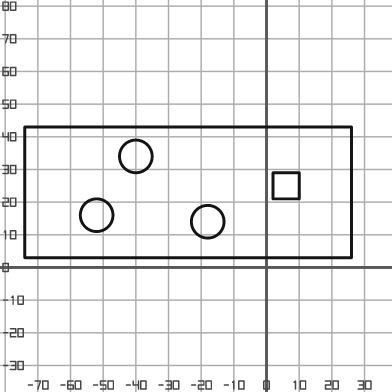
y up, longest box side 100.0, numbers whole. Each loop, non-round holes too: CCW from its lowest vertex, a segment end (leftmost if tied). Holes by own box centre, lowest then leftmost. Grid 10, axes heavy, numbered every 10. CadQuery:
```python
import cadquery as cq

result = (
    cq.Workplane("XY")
    .moveTo(-74.0, 3.0)
    .lineTo(26.0, 3.0)
    .lineTo(26.0, 43.0)
    .lineTo(-74.0, 43.0)
    .close()
    .moveTo(-18.0, 14.0)
    .circle(5.0)
    .moveTo(-52.0, 16.0)
    .circle(5.0)
    .moveTo(2.0, 21.0)
    .lineTo(10.0, 21.0)
    .lineTo(10.0, 29.0)
    .lineTo(2.0, 29.0)
    .close()
    .moveTo(-40.0, 34.0)
    .circle(5.0)
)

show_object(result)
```